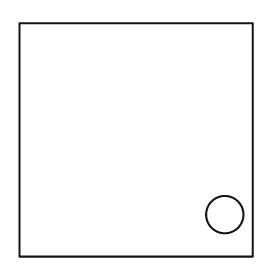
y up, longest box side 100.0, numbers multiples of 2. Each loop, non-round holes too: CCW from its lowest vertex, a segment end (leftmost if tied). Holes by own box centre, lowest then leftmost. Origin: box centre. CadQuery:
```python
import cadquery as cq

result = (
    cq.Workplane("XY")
    .moveTo(-50.0, -50.0)
    .lineTo(50.0, -50.0)
    .lineTo(50.0, 50.0)
    .lineTo(-50.0, 50.0)
    .close()
    .moveTo(38.0, -32.0)
    .circle(8.0)
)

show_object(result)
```